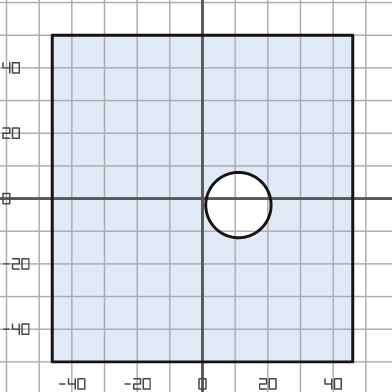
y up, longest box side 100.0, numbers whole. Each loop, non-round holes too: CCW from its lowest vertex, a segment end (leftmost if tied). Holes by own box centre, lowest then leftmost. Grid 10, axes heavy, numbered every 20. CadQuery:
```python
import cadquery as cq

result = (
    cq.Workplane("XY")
    .moveTo(-46.0, -50.0)
    .lineTo(46.0, -50.0)
    .lineTo(46.0, 50.0)
    .lineTo(-46.0, 50.0)
    .close()
    .moveTo(11.0, -2.0)
    .circle(10.0)
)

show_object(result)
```